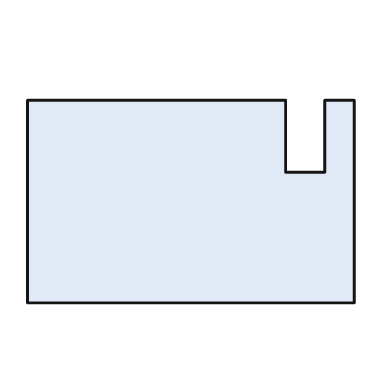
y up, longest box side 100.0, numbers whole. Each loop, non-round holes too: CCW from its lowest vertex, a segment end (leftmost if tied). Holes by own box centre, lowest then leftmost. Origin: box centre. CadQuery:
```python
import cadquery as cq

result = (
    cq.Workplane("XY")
    .moveTo(-50.0, -31.0)
    .lineTo(50.0, -31.0)
    .lineTo(50.0, 31.0)
    .lineTo(41.0, 31.0)
    .lineTo(41.0, 9.0)
    .lineTo(29.0, 9.0)
    .lineTo(29.0, 31.0)
    .lineTo(-50.0, 31.0)
    .close()
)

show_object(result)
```